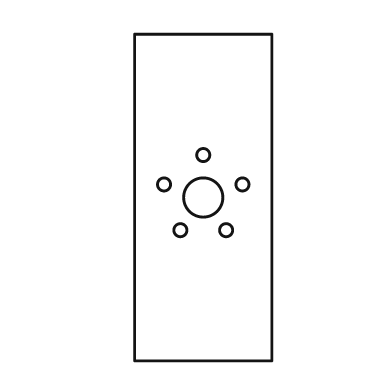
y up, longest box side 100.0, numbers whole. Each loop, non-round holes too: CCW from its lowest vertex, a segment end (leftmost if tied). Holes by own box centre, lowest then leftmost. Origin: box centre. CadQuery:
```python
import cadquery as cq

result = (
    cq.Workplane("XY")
    .moveTo(-21.0, -50.0)
    .lineTo(21.0, -50.0)
    .lineTo(21.0, 50.0)
    .lineTo(-21.0, 50.0)
    .close()
    .moveTo(-7.0, -10.0)
    .circle(2.0)
    .moveTo(7.0, -10.0)
    .circle(2.0)
    .moveTo(0.0, 0.0)
    .circle(6.0)
    .moveTo(-12.0, 4.0)
    .circle(2.0)
    .moveTo(12.0, 4.0)
    .circle(2.0)
    .moveTo(0.0, 13.0)
    .circle(2.0)
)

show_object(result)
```